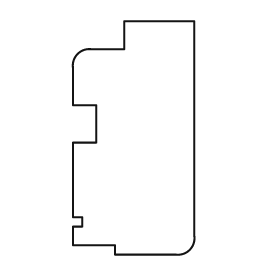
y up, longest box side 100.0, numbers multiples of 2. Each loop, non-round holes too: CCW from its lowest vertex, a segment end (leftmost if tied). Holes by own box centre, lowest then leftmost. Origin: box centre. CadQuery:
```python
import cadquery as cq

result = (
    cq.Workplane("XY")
    .moveTo(-8.0, -50.0)
    .lineTo(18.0, -50.0)
    .threePointArc((24.0, -48.0), (26.0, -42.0))
    .lineTo(26.0, 50.0)
    .lineTo(-4.0, 50.0)
    .lineTo(-4.0, 38.0)
    .lineTo(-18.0, 38.0)
    .threePointArc((-24.0, 36.0), (-26.0, 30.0))
    .lineTo(-26.0, 14.0)
    .lineTo(-16.0, 14.0)
    .lineTo(-16.0, -2.0)
    .lineTo(-26.0, -2.0)
    .lineTo(-26.0, -34.0)
    .lineTo(-22.0, -34.0)
    .lineTo(-22.0, -38.0)
    .lineTo(-26.0, -38.0)
    .lineTo(-26.0, -46.0)
    .lineTo(-8.0, -46.0)
    .close()
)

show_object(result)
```